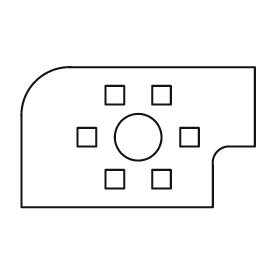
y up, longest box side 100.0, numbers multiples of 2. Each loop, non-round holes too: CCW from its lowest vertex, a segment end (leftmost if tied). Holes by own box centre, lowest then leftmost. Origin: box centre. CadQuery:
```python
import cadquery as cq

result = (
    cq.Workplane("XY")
    .moveTo(-50.0, -30.0)
    .lineTo(32.0, -30.0)
    .lineTo(32.0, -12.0)
    .threePointArc((34.0, -6.0), (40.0, -4.0))
    .lineTo(50.0, -4.0)
    .lineTo(50.0, 30.0)
    .lineTo(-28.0, 30.0)
    .threePointArc((-44.0, 24.0), (-50.0, 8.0))
    .close()
    .moveTo(-14.0, -22.0)
    .lineTo(-6.0, -22.0)
    .lineTo(-6.0, -14.0)
    .lineTo(-14.0, -14.0)
    .close()
    .moveTo(6.0, -22.0)
    .lineTo(14.0, -22.0)
    .lineTo(14.0, -14.0)
    .lineTo(6.0, -14.0)
    .close()
    .moveTo(-26.0, -4.0)
    .lineTo(-18.0, -4.0)
    .lineTo(-18.0, 4.0)
    .lineTo(-26.0, 4.0)
    .close()
    .moveTo(0.0, 0.0)
    .circle(10.0)
    .moveTo(18.0, -4.0)
    .lineTo(26.0, -4.0)
    .lineTo(26.0, 4.0)
    .lineTo(18.0, 4.0)
    .close()
    .moveTo(-14.0, 14.0)
    .lineTo(-6.0, 14.0)
    .lineTo(-6.0, 22.0)
    .lineTo(-14.0, 22.0)
    .close()
    .moveTo(6.0, 14.0)
    .lineTo(14.0, 14.0)
    .lineTo(14.0, 22.0)
    .lineTo(6.0, 22.0)
    .close()
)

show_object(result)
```